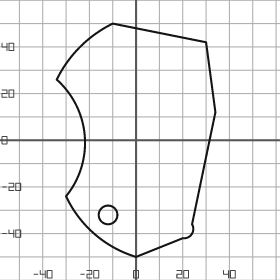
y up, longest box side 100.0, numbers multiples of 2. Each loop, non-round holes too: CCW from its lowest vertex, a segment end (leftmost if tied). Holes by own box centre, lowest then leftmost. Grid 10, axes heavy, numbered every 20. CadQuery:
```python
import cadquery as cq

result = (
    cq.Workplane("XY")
    .moveTo(0.0, -50.0)
    .lineTo(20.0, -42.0)
    .threePointArc((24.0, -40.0), (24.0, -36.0))
    .lineTo(34.0, 12.0)
    .lineTo(30.0, 42.0)
    .lineTo(-10.0, 50.0)
    .threePointArc((-24.0, 40.0), (-34.0, 26.0))
    .threePointArc((-22.0, 2.0), (-30.0, -24.0))
    .threePointArc((-18.0, -40.0), (0.0, -50.0))
    .close()
    .moveTo(-12.0, -32.0)
    .circle(4.0)
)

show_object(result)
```